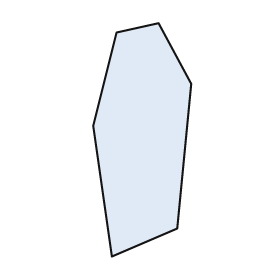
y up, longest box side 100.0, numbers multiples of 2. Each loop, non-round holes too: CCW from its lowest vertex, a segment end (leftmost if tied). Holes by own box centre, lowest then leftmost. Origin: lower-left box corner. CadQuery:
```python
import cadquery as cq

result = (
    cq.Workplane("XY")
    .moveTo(8.0, 0.0)
    .lineTo(36.0, 12.0)
    .lineTo(42.0, 74.0)
    .lineTo(28.0, 100.0)
    .lineTo(10.0, 96.0)
    .lineTo(0.0, 56.0)
    .close()
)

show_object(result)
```